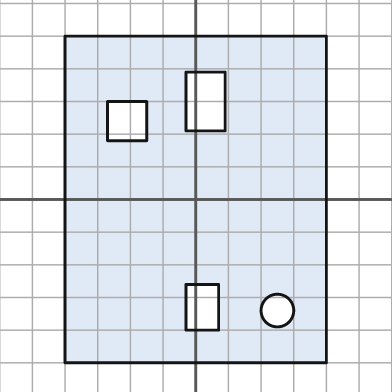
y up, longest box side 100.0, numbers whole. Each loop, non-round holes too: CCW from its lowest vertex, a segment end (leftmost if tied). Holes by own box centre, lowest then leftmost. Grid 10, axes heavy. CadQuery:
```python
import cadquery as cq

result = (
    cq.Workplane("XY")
    .moveTo(-40.0, -50.0)
    .lineTo(40.0, -50.0)
    .lineTo(40.0, 50.0)
    .lineTo(-40.0, 50.0)
    .close()
    .moveTo(25.0, -34.0)
    .circle(5.0)
    .moveTo(-3.0, -40.0)
    .lineTo(7.0, -40.0)
    .lineTo(7.0, -26.0)
    .lineTo(-3.0, -26.0)
    .close()
    .moveTo(-27.0, 18.0)
    .lineTo(-15.0, 18.0)
    .lineTo(-15.0, 30.0)
    .lineTo(-27.0, 30.0)
    .close()
    .moveTo(-3.0, 21.0)
    .lineTo(9.0, 21.0)
    .lineTo(9.0, 39.0)
    .lineTo(-3.0, 39.0)
    .close()
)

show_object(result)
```